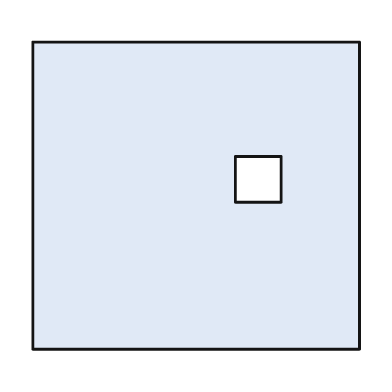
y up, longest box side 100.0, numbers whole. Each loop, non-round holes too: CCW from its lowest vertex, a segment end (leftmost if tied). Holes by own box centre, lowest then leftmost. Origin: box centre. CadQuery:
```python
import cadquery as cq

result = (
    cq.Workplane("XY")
    .moveTo(-50.0, -47.0)
    .lineTo(50.0, -47.0)
    .lineTo(50.0, 47.0)
    .lineTo(-50.0, 47.0)
    .close()
    .moveTo(12.0, -2.0)
    .lineTo(26.0, -2.0)
    .lineTo(26.0, 12.0)
    .lineTo(12.0, 12.0)
    .close()
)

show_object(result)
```